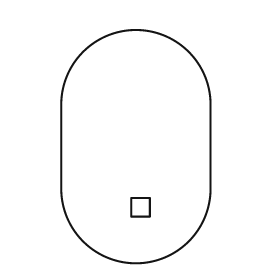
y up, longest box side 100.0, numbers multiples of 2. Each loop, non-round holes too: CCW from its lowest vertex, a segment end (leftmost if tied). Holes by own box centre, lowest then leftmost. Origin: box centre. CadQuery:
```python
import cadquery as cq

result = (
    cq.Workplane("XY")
    .moveTo(-32.0, -18.0)
    .threePointArc((0.0, -50.0), (32.0, -18.0))
    .lineTo(32.0, 18.0)
    .threePointArc((0.0, 50.0), (-32.0, 18.0))
    .close()
    .moveTo(-2.0, -30.0)
    .lineTo(6.0, -30.0)
    .lineTo(6.0, -22.0)
    .lineTo(-2.0, -22.0)
    .close()
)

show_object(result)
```